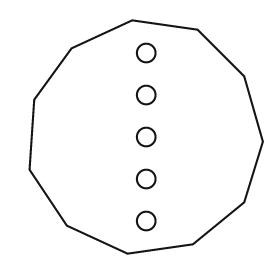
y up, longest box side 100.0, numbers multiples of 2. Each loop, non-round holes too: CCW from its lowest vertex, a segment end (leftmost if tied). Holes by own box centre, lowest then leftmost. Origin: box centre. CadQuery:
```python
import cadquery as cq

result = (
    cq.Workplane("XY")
    .moveTo(-8.0, -50.0)
    .lineTo(20.0, -46.0)
    .lineTo(42.0, -28.0)
    .lineTo(50.0, -2.0)
    .lineTo(42.0, 26.0)
    .lineTo(22.0, 46.0)
    .lineTo(-6.0, 50.0)
    .lineTo(-32.0, 38.0)
    .lineTo(-48.0, 16.0)
    .lineTo(-50.0, -14.0)
    .lineTo(-34.0, -38.0)
    .close()
    .moveTo(0.0, -36.0)
    .circle(4.0)
    .moveTo(0.0, -18.0)
    .circle(4.0)
    .moveTo(0.0, 0.0)
    .circle(4.0)
    .moveTo(0.0, 18.0)
    .circle(4.0)
    .moveTo(0.0, 36.0)
    .circle(4.0)
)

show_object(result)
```